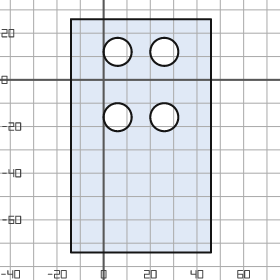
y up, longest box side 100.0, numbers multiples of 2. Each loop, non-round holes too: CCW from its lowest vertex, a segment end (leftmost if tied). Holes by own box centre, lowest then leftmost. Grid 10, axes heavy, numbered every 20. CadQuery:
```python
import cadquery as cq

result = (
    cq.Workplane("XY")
    .moveTo(-14.0, -74.0)
    .lineTo(46.0, -74.0)
    .lineTo(46.0, 26.0)
    .lineTo(-14.0, 26.0)
    .close()
    .moveTo(6.0, -16.0)
    .circle(6.0)
    .moveTo(26.0, -16.0)
    .circle(6.0)
    .moveTo(6.0, 12.0)
    .circle(6.0)
    .moveTo(26.0, 12.0)
    .circle(6.0)
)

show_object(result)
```